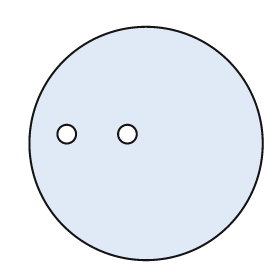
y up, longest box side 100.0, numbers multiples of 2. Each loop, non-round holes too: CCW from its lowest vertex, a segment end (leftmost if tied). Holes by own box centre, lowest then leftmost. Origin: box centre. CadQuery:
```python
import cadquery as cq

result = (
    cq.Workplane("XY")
    .moveTo(0.0, 0.0)
    .circle(50.0)
    .moveTo(-34.0, 4.0)
    .circle(4.0)
    .moveTo(-8.0, 4.0)
    .circle(4.0)
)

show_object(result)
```